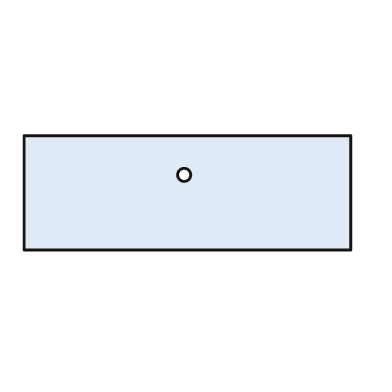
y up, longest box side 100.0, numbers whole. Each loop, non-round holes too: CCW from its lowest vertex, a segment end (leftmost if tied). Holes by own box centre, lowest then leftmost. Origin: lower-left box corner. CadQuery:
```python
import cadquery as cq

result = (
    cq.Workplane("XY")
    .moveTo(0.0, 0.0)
    .lineTo(100.0, 0.0)
    .lineTo(100.0, 35.0)
    .lineTo(0.0, 35.0)
    .close()
    .moveTo(49.0, 23.0)
    .circle(2.0)
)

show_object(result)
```